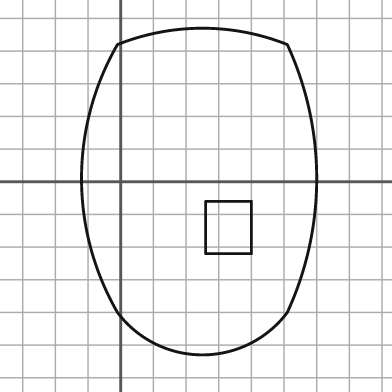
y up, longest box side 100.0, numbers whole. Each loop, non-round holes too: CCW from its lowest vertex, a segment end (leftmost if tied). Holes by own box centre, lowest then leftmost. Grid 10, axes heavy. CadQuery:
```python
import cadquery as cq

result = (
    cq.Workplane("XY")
    .moveTo(-1.0, -40.0)
    .threePointArc((25.0, -53.0), (51.0, -40.0))
    .threePointArc((60.0, 1.0), (51.0, 42.0))
    .threePointArc((25.0, 47.0), (-1.0, 42.0))
    .threePointArc((-12.0, 1.0), (-1.0, -40.0))
    .close()
    .moveTo(26.0, -22.0)
    .lineTo(40.0, -22.0)
    .lineTo(40.0, -6.0)
    .lineTo(26.0, -6.0)
    .close()
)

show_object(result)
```